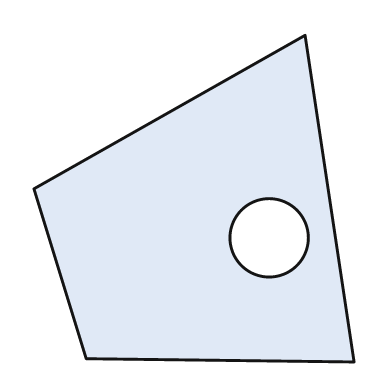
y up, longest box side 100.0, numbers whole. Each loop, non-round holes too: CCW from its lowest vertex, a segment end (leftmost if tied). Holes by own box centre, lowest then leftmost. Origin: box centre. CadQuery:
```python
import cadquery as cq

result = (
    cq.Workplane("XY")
    .moveTo(49.0, -50.0)
    .lineTo(34.0, 50.0)
    .lineTo(-49.0, 3.0)
    .lineTo(-33.0, -49.0)
    .close()
    .moveTo(23.0, -12.0)
    .circle(12.0)
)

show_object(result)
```